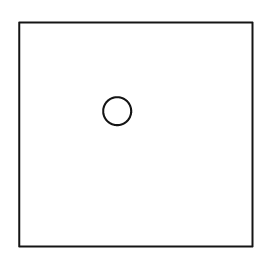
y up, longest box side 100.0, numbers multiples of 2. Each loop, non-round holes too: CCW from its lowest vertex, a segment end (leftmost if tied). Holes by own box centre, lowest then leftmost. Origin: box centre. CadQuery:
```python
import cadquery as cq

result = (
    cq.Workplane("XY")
    .moveTo(-50.0, -48.0)
    .lineTo(50.0, -48.0)
    .lineTo(50.0, 48.0)
    .lineTo(-50.0, 48.0)
    .close()
    .moveTo(-8.0, 10.0)
    .circle(6.0)
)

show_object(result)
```